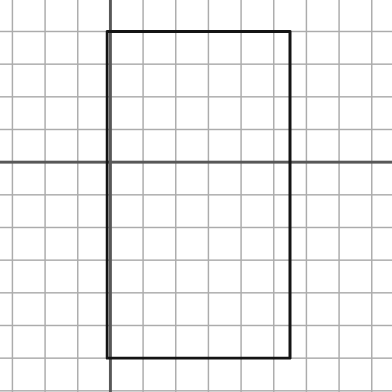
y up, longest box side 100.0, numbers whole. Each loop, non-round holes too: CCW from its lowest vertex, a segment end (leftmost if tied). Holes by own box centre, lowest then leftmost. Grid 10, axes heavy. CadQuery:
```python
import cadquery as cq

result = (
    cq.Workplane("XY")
    .moveTo(-1.0, -60.0)
    .lineTo(55.0, -60.0)
    .lineTo(55.0, 40.0)
    .lineTo(-1.0, 40.0)
    .close()
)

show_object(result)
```